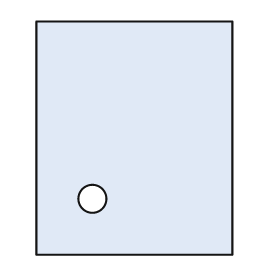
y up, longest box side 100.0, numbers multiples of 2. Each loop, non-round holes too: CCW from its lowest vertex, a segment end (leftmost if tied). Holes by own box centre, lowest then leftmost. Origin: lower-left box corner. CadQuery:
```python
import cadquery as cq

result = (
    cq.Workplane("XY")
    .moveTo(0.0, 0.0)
    .lineTo(84.0, 0.0)
    .lineTo(84.0, 100.0)
    .lineTo(0.0, 100.0)
    .close()
    .moveTo(24.0, 24.0)
    .circle(6.0)
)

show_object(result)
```